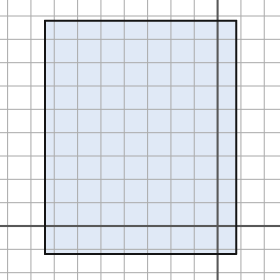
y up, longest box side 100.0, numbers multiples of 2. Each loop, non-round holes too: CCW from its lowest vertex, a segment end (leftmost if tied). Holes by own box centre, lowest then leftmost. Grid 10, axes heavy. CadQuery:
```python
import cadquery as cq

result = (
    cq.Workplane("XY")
    .moveTo(-74.0, -12.0)
    .lineTo(8.0, -12.0)
    .lineTo(8.0, 88.0)
    .lineTo(-74.0, 88.0)
    .close()
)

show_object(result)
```